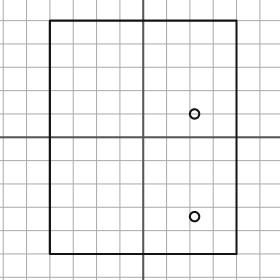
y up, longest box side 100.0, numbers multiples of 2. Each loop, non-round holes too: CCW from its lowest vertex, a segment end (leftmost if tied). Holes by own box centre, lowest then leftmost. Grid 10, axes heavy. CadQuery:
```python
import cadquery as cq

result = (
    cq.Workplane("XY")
    .moveTo(-40.0, -50.0)
    .lineTo(40.0, -50.0)
    .lineTo(40.0, 50.0)
    .lineTo(-40.0, 50.0)
    .close()
    .moveTo(22.0, -34.0)
    .circle(2.0)
    .moveTo(22.0, 10.0)
    .circle(2.0)
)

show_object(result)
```